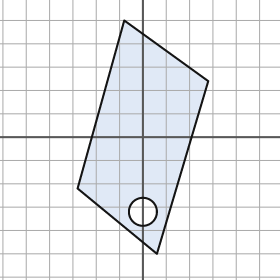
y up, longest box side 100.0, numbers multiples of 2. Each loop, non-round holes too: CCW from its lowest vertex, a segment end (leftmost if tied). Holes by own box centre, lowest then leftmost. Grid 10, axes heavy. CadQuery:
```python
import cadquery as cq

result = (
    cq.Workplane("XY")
    .moveTo(6.0, -50.0)
    .lineTo(28.0, 24.0)
    .lineTo(-8.0, 50.0)
    .lineTo(-28.0, -22.0)
    .close()
    .moveTo(0.0, -32.0)
    .circle(6.0)
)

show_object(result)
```